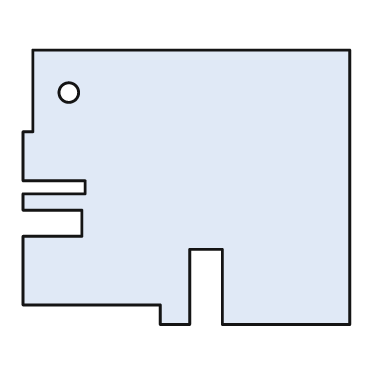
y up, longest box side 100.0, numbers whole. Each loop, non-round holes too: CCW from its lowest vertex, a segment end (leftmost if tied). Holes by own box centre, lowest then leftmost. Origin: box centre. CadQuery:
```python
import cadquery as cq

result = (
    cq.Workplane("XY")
    .moveTo(-8.0, -42.0)
    .lineTo(1.0, -42.0)
    .lineTo(1.0, -19.0)
    .lineTo(11.0, -19.0)
    .lineTo(11.0, -42.0)
    .lineTo(50.0, -42.0)
    .lineTo(50.0, 42.0)
    .lineTo(-47.0, 42.0)
    .lineTo(-47.0, 17.0)
    .lineTo(-50.0, 17.0)
    .lineTo(-50.0, 2.0)
    .lineTo(-31.0, 2.0)
    .lineTo(-31.0, -2.0)
    .lineTo(-50.0, -2.0)
    .lineTo(-50.0, -7.0)
    .lineTo(-32.0, -7.0)
    .lineTo(-32.0, -15.0)
    .lineTo(-50.0, -15.0)
    .lineTo(-50.0, -36.0)
    .lineTo(-8.0, -36.0)
    .close()
    .moveTo(-36.0, 29.0)
    .circle(3.0)
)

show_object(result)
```